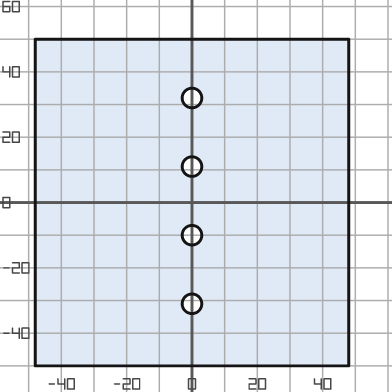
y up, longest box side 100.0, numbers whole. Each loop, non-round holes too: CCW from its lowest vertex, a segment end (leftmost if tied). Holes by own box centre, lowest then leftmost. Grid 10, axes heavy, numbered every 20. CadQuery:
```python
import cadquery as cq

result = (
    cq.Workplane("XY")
    .moveTo(-48.0, -50.0)
    .lineTo(48.0, -50.0)
    .lineTo(48.0, 50.0)
    .lineTo(-48.0, 50.0)
    .close()
    .moveTo(0.0, -31.0)
    .circle(3.0)
    .moveTo(0.0, -10.0)
    .circle(3.0)
    .moveTo(0.0, 11.0)
    .circle(3.0)
    .moveTo(0.0, 32.0)
    .circle(3.0)
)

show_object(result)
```